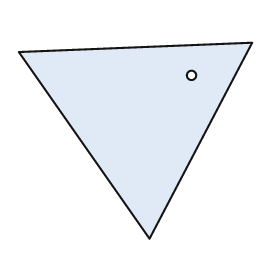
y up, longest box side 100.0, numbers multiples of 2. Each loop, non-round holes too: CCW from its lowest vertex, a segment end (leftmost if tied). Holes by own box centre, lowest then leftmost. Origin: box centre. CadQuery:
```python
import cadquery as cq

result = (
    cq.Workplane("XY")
    .moveTo(6.0, -42.0)
    .lineTo(50.0, 42.0)
    .lineTo(-50.0, 38.0)
    .close()
    .moveTo(24.0, 28.0)
    .circle(2.0)
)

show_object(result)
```